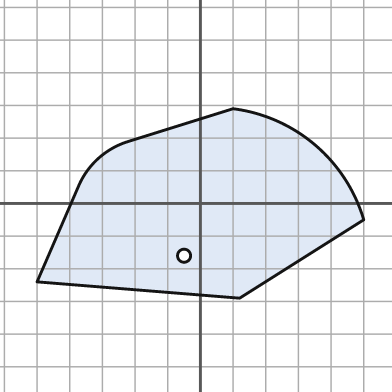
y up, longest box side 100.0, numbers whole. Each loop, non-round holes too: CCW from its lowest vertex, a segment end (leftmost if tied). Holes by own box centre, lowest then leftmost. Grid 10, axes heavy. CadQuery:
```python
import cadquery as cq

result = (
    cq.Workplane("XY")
    .moveTo(12.0, -29.0)
    .lineTo(50.0, -5.0)
    .threePointArc((35.0, 18.0), (10.0, 29.0))
    .lineTo(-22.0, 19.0)
    .threePointArc((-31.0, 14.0), (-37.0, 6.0))
    .lineTo(-50.0, -24.0)
    .close()
    .moveTo(-5.0, -16.0)
    .circle(2.0)
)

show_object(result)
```